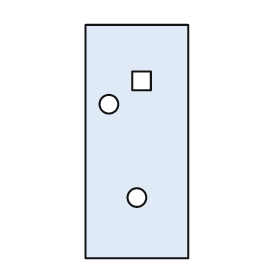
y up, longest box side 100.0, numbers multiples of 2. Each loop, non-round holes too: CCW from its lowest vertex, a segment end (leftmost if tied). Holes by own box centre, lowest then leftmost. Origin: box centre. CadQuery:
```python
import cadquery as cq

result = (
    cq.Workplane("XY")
    .moveTo(-22.0, -50.0)
    .lineTo(22.0, -50.0)
    .lineTo(22.0, 50.0)
    .lineTo(-22.0, 50.0)
    .close()
    .moveTo(0.0, -24.0)
    .circle(4.0)
    .moveTo(-12.0, 16.0)
    .circle(4.0)
    .moveTo(-2.0, 22.0)
    .lineTo(6.0, 22.0)
    .lineTo(6.0, 30.0)
    .lineTo(-2.0, 30.0)
    .close()
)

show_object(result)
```